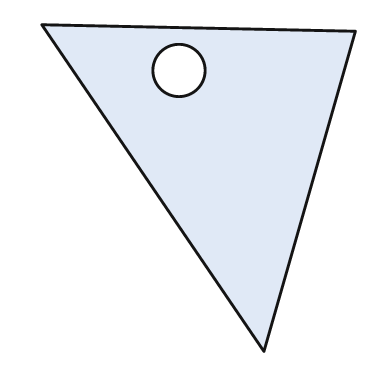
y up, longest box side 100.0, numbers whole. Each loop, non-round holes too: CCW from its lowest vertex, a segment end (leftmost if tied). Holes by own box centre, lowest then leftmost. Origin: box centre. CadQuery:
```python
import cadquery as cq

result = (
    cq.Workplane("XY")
    .moveTo(20.0, -50.0)
    .lineTo(48.0, 48.0)
    .lineTo(-48.0, 50.0)
    .close()
    .moveTo(-6.0, 36.0)
    .circle(8.0)
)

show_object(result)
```